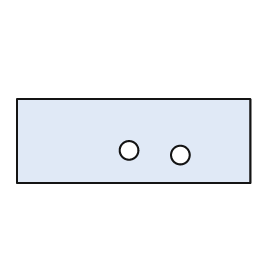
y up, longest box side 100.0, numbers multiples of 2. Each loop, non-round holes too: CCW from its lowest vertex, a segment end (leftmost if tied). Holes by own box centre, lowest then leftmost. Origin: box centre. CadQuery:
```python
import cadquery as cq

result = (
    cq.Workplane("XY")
    .moveTo(-50.0, -18.0)
    .lineTo(50.0, -18.0)
    .lineTo(50.0, 18.0)
    .lineTo(-50.0, 18.0)
    .close()
    .moveTo(20.0, -6.0)
    .circle(4.0)
    .moveTo(-2.0, -4.0)
    .circle(4.0)
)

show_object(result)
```